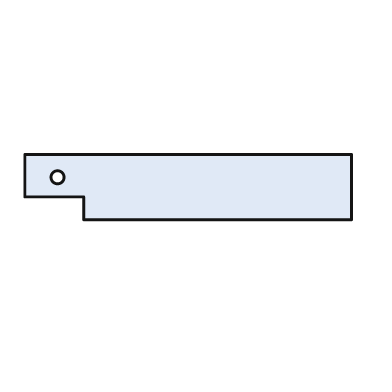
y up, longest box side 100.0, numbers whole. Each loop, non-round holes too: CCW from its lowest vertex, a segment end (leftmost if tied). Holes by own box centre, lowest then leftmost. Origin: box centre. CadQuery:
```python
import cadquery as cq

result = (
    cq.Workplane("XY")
    .moveTo(-32.0, -10.0)
    .lineTo(50.0, -10.0)
    .lineTo(50.0, 10.0)
    .lineTo(-50.0, 10.0)
    .lineTo(-50.0, -3.0)
    .lineTo(-32.0, -3.0)
    .close()
    .moveTo(-40.0, 3.0)
    .circle(2.0)
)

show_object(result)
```